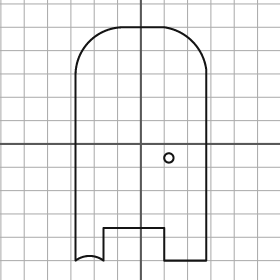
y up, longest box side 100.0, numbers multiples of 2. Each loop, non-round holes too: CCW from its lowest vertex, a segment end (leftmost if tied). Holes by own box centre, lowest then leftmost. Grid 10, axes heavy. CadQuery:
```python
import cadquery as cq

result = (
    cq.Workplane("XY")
    .moveTo(-28.0, -50.0)
    .threePointArc((-22.0, -48.0), (-16.0, -50.0))
    .lineTo(-16.0, -36.0)
    .lineTo(10.0, -36.0)
    .lineTo(10.0, -50.0)
    .lineTo(28.0, -50.0)
    .lineTo(28.0, 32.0)
    .threePointArc((22.0, 44.0), (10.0, 50.0))
    .lineTo(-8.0, 50.0)
    .threePointArc((-22.0, 44.0), (-28.0, 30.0))
    .close()
    .moveTo(12.0, -6.0)
    .circle(2.0)
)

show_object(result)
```